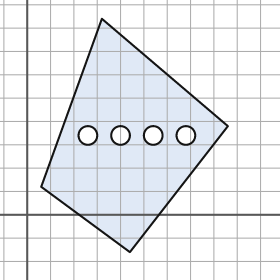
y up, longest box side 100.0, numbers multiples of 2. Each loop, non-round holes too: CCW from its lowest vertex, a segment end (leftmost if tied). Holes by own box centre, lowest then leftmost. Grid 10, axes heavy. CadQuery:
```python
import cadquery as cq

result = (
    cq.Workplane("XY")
    .moveTo(44.0, -16.0)
    .lineTo(86.0, 38.0)
    .lineTo(32.0, 84.0)
    .lineTo(6.0, 12.0)
    .close()
    .moveTo(26.0, 34.0)
    .circle(4.0)
    .moveTo(40.0, 34.0)
    .circle(4.0)
    .moveTo(54.0, 34.0)
    .circle(4.0)
    .moveTo(68.0, 34.0)
    .circle(4.0)
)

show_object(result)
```